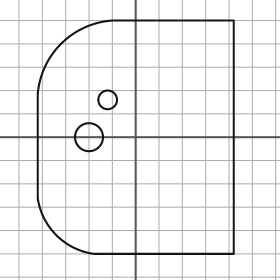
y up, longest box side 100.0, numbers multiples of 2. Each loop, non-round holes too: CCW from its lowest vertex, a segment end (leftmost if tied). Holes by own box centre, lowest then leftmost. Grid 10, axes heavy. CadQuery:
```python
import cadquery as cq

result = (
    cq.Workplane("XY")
    .moveTo(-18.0, -50.0)
    .lineTo(42.0, -50.0)
    .lineTo(42.0, 50.0)
    .lineTo(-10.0, 50.0)
    .threePointArc((-32.0, 40.0), (-42.0, 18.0))
    .lineTo(-42.0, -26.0)
    .threePointArc((-34.0, -42.0), (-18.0, -50.0))
    .close()
    .moveTo(-20.0, 0.0)
    .circle(6.0)
    .moveTo(-12.0, 16.0)
    .circle(4.0)
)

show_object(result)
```